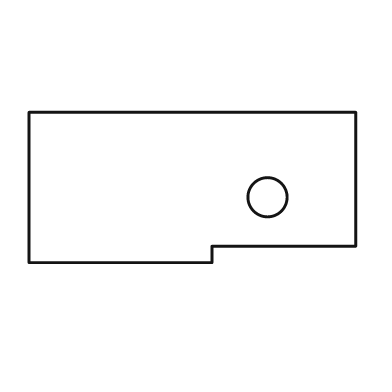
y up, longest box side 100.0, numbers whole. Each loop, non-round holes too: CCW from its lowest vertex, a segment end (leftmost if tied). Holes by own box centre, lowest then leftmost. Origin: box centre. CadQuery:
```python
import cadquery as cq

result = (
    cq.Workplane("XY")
    .moveTo(-50.0, -23.0)
    .lineTo(6.0, -23.0)
    .lineTo(6.0, -18.0)
    .lineTo(50.0, -18.0)
    .lineTo(50.0, 23.0)
    .lineTo(-50.0, 23.0)
    .close()
    .moveTo(23.0, -3.0)
    .circle(6.0)
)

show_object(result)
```